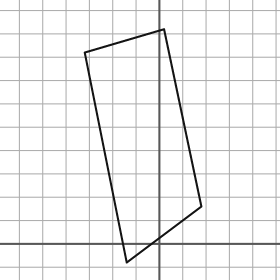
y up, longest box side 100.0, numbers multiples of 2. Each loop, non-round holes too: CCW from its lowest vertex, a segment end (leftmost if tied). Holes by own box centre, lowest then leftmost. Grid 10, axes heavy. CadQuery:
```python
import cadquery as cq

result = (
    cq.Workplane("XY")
    .moveTo(-14.0, -8.0)
    .lineTo(18.0, 16.0)
    .lineTo(2.0, 92.0)
    .lineTo(-32.0, 82.0)
    .close()
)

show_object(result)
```